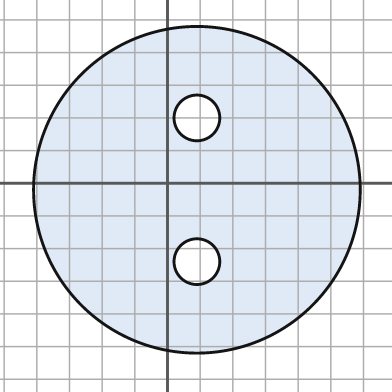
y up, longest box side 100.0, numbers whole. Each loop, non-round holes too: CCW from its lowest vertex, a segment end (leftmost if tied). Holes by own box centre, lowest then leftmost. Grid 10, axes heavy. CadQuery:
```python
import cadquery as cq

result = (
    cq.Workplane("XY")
    .moveTo(9.0, -2.0)
    .circle(50.0)
    .moveTo(9.0, -24.0)
    .circle(7.0)
    .moveTo(9.0, 20.0)
    .circle(7.0)
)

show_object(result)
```